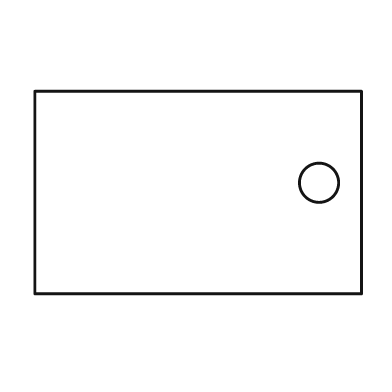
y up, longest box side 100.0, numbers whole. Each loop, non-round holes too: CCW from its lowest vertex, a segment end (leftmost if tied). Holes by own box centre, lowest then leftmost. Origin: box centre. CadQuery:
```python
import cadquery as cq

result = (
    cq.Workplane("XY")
    .moveTo(-50.0, -31.0)
    .lineTo(50.0, -31.0)
    .lineTo(50.0, 31.0)
    .lineTo(-50.0, 31.0)
    .close()
    .moveTo(37.0, 3.0)
    .circle(6.0)
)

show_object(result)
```